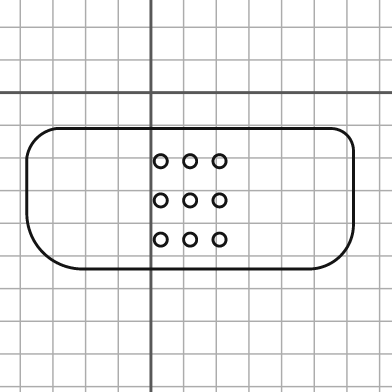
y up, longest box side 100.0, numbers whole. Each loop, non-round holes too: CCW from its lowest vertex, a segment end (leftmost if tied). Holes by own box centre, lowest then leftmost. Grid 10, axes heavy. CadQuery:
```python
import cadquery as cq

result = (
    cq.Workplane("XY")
    .moveTo(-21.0, -54.0)
    .lineTo(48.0, -54.0)
    .threePointArc((58.0, -50.0), (62.0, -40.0))
    .lineTo(62.0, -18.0)
    .threePointArc((60.0, -13.0), (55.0, -11.0))
    .lineTo(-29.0, -11.0)
    .threePointArc((-35.0, -14.0), (-38.0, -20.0))
    .lineTo(-38.0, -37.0)
    .threePointArc((-33.0, -49.0), (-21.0, -54.0))
    .close()
    .moveTo(3.0, -45.0)
    .circle(2.0)
    .moveTo(12.0, -45.0)
    .circle(2.0)
    .moveTo(21.0, -45.0)
    .circle(2.0)
    .moveTo(3.0, -33.0)
    .circle(2.0)
    .moveTo(12.0, -33.0)
    .circle(2.0)
    .moveTo(21.0, -33.0)
    .circle(2.0)
    .moveTo(3.0, -21.0)
    .circle(2.0)
    .moveTo(12.0, -21.0)
    .circle(2.0)
    .moveTo(21.0, -21.0)
    .circle(2.0)
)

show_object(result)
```